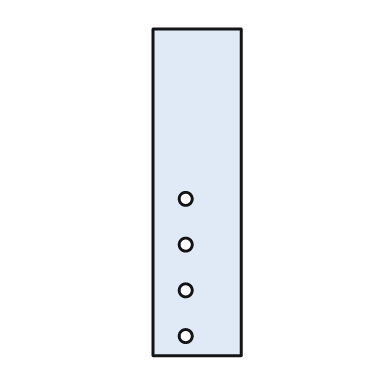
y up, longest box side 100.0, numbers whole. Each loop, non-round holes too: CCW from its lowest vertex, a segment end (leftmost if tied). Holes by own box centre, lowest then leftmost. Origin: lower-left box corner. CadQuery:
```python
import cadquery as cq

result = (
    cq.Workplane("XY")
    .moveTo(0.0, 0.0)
    .lineTo(27.0, 0.0)
    .lineTo(27.0, 100.0)
    .lineTo(0.0, 100.0)
    .close()
    .moveTo(10.0, 6.0)
    .circle(2.0)
    .moveTo(10.0, 20.0)
    .circle(2.0)
    .moveTo(10.0, 34.0)
    .circle(2.0)
    .moveTo(10.0, 48.0)
    .circle(2.0)
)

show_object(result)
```